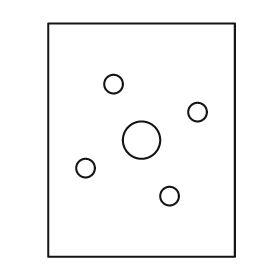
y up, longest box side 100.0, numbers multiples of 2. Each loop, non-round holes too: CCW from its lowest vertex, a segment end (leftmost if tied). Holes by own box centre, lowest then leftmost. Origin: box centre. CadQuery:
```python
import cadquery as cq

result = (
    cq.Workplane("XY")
    .moveTo(-40.0, -50.0)
    .lineTo(40.0, -50.0)
    .lineTo(40.0, 50.0)
    .lineTo(-40.0, 50.0)
    .close()
    .moveTo(12.0, -24.0)
    .circle(4.0)
    .moveTo(-24.0, -12.0)
    .circle(4.0)
    .moveTo(0.0, 0.0)
    .circle(8.0)
    .moveTo(24.0, 12.0)
    .circle(4.0)
    .moveTo(-12.0, 24.0)
    .circle(4.0)
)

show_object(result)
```